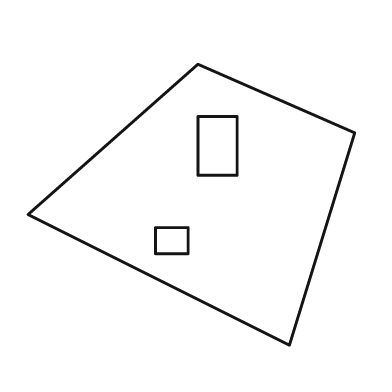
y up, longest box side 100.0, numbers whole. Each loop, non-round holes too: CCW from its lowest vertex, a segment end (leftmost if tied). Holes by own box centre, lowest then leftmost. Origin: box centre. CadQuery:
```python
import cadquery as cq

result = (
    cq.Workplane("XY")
    .moveTo(30.0, -43.0)
    .lineTo(50.0, 22.0)
    .lineTo(2.0, 43.0)
    .lineTo(-50.0, -3.0)
    .close()
    .moveTo(-11.0, -15.0)
    .lineTo(-1.0, -15.0)
    .lineTo(-1.0, -7.0)
    .lineTo(-11.0, -7.0)
    .close()
    .moveTo(2.0, 9.0)
    .lineTo(14.0, 9.0)
    .lineTo(14.0, 27.0)
    .lineTo(2.0, 27.0)
    .close()
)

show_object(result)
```